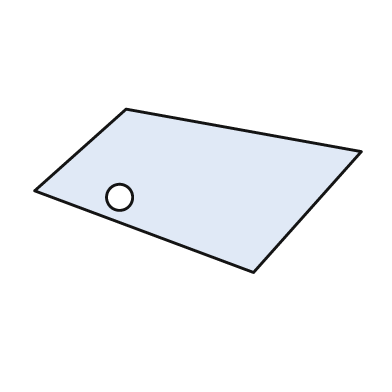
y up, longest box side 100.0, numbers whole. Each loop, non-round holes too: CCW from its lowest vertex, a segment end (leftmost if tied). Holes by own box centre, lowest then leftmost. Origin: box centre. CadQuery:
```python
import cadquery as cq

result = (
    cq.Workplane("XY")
    .moveTo(17.0, -25.0)
    .lineTo(50.0, 12.0)
    .lineTo(-22.0, 25.0)
    .lineTo(-50.0, 0.0)
    .close()
    .moveTo(-24.0, -2.0)
    .circle(4.0)
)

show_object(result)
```